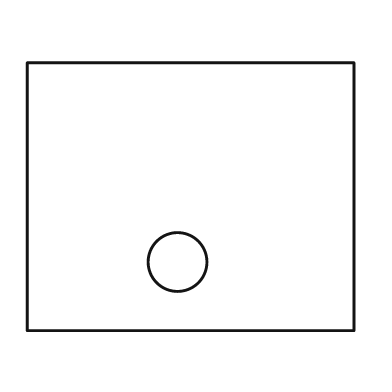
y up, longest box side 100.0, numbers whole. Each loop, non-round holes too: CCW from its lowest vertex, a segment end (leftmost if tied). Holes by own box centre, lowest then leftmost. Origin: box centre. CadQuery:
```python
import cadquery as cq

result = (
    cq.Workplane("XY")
    .moveTo(-50.0, -41.0)
    .lineTo(50.0, -41.0)
    .lineTo(50.0, 41.0)
    .lineTo(-50.0, 41.0)
    .close()
    .moveTo(-4.0, -20.0)
    .circle(9.0)
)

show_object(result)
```